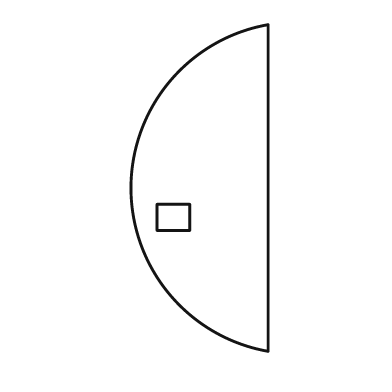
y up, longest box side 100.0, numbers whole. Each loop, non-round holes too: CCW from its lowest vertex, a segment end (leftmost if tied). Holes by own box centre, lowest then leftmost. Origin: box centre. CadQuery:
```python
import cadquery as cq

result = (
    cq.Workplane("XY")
    .moveTo(21.0, -50.0)
    .lineTo(21.0, 50.0)
    .threePointArc((-21.0, 0.0), (21.0, -50.0))
    .close()
    .moveTo(-13.0, -13.0)
    .lineTo(-3.0, -13.0)
    .lineTo(-3.0, -5.0)
    .lineTo(-13.0, -5.0)
    .close()
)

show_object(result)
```